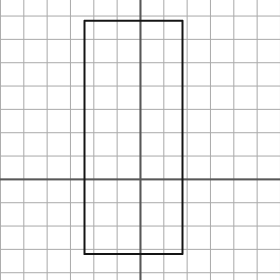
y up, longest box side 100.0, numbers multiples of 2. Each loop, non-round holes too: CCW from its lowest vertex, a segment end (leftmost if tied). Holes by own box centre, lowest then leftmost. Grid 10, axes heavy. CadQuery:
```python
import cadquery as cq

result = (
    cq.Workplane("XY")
    .moveTo(-24.0, -32.0)
    .lineTo(18.0, -32.0)
    .lineTo(18.0, 68.0)
    .lineTo(-24.0, 68.0)
    .close()
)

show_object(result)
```